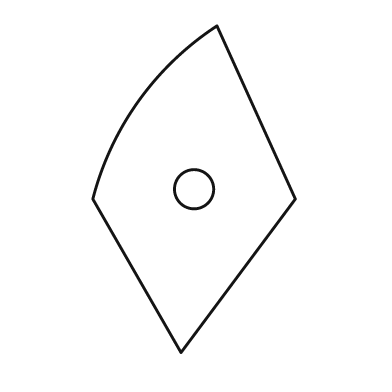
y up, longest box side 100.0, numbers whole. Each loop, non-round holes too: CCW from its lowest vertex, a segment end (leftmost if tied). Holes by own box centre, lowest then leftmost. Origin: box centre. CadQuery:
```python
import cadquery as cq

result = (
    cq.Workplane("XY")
    .moveTo(-4.0, -50.0)
    .lineTo(31.0, -3.0)
    .lineTo(7.0, 50.0)
    .threePointArc((-17.0, 27.0), (-31.0, -3.0))
    .close()
    .moveTo(0.0, 0.0)
    .circle(6.0)
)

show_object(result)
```